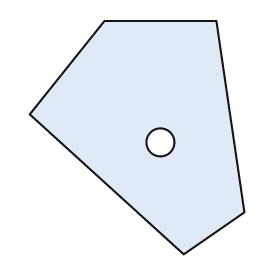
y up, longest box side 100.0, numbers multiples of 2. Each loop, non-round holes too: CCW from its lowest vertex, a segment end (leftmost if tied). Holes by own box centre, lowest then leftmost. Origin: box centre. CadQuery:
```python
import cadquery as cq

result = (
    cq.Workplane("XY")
    .moveTo(20.0, -50.0)
    .lineTo(46.0, -32.0)
    .lineTo(34.0, 50.0)
    .lineTo(-14.0, 50.0)
    .lineTo(-46.0, 10.0)
    .close()
    .moveTo(10.0, -2.0)
    .circle(6.0)
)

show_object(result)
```